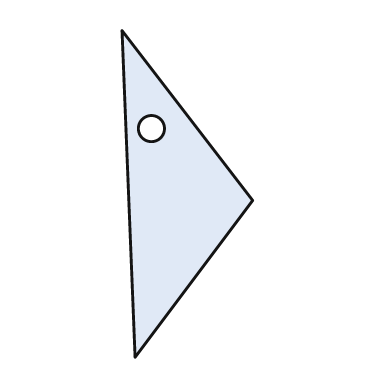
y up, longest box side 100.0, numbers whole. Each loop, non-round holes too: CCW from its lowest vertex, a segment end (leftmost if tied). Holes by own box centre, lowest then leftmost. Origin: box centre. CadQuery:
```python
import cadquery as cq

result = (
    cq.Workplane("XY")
    .moveTo(-16.0, -50.0)
    .lineTo(20.0, -2.0)
    .lineTo(-20.0, 50.0)
    .close()
    .moveTo(-11.0, 20.0)
    .circle(4.0)
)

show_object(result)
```